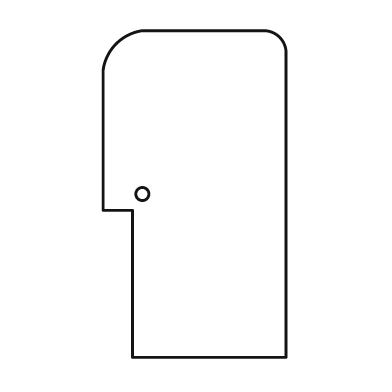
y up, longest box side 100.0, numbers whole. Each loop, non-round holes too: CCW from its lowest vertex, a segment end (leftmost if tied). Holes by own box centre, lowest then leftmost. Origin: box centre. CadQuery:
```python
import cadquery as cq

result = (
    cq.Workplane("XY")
    .moveTo(-19.0, -50.0)
    .lineTo(28.0, -50.0)
    .lineTo(28.0, 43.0)
    .threePointArc((26.0, 48.0), (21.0, 50.0))
    .lineTo(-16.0, 50.0)
    .threePointArc((-24.0, 46.0), (-28.0, 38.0))
    .lineTo(-28.0, -5.0)
    .lineTo(-19.0, -5.0)
    .close()
    .moveTo(-16.0, 0.0)
    .circle(2.0)
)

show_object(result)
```